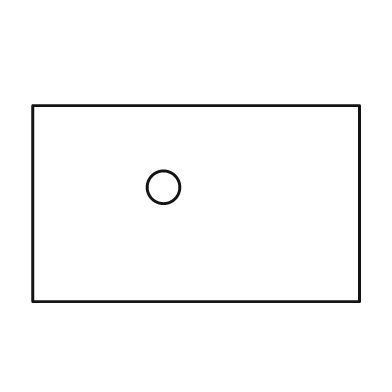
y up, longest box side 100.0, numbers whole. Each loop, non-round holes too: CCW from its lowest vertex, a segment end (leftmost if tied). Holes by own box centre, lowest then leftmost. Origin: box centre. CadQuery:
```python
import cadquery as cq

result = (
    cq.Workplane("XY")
    .moveTo(-50.0, -30.0)
    .lineTo(50.0, -30.0)
    .lineTo(50.0, 30.0)
    .lineTo(-50.0, 30.0)
    .close()
    .moveTo(-10.0, 5.0)
    .circle(5.0)
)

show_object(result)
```